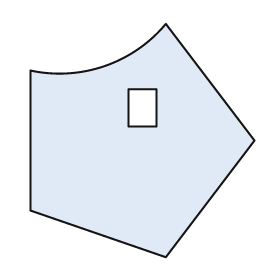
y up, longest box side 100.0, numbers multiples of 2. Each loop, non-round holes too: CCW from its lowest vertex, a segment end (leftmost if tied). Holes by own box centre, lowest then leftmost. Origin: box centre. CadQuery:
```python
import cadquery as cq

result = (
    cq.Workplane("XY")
    .moveTo(10.0, -50.0)
    .lineTo(48.0, 0.0)
    .lineTo(10.0, 50.0)
    .threePointArc((-16.0, 32.0), (-48.0, 30.0))
    .lineTo(-48.0, -30.0)
    .close()
    .moveTo(-6.0, 6.0)
    .lineTo(6.0, 6.0)
    .lineTo(6.0, 22.0)
    .lineTo(-6.0, 22.0)
    .close()
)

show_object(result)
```